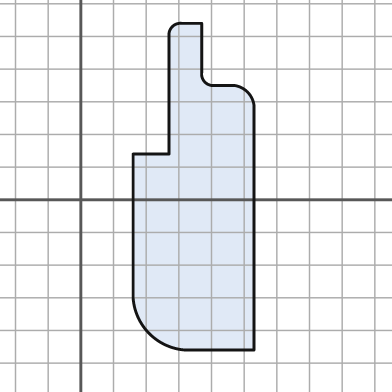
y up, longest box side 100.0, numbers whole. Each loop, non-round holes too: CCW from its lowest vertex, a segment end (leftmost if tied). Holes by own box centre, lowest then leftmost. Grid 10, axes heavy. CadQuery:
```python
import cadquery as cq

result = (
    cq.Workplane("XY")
    .moveTo(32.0, -46.0)
    .lineTo(53.0, -46.0)
    .lineTo(53.0, 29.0)
    .threePointArc((51.0, 33.0), (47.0, 35.0))
    .lineTo(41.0, 35.0)
    .threePointArc((38.0, 36.0), (37.0, 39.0))
    .lineTo(37.0, 54.0)
    .lineTo(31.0, 54.0)
    .threePointArc((28.0, 53.0), (27.0, 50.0))
    .lineTo(27.0, 14.0)
    .lineTo(16.0, 14.0)
    .lineTo(16.0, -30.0)
    .threePointArc((21.0, -41.0), (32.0, -46.0))
    .close()
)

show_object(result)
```